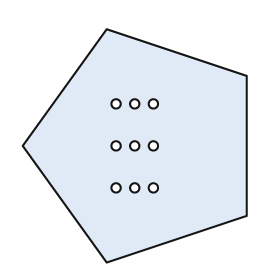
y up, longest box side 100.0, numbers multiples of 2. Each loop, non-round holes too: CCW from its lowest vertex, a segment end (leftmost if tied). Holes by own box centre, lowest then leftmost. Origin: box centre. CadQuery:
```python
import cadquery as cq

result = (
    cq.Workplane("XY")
    .moveTo(-12.0, -50.0)
    .lineTo(48.0, -30.0)
    .lineTo(48.0, 30.0)
    .lineTo(-12.0, 50.0)
    .lineTo(-48.0, 0.0)
    .close()
    .moveTo(-8.0, -18.0)
    .circle(2.0)
    .moveTo(0.0, -18.0)
    .circle(2.0)
    .moveTo(8.0, -18.0)
    .circle(2.0)
    .moveTo(-8.0, 0.0)
    .circle(2.0)
    .moveTo(0.0, 0.0)
    .circle(2.0)
    .moveTo(8.0, 0.0)
    .circle(2.0)
    .moveTo(-8.0, 18.0)
    .circle(2.0)
    .moveTo(0.0, 18.0)
    .circle(2.0)
    .moveTo(8.0, 18.0)
    .circle(2.0)
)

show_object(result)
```